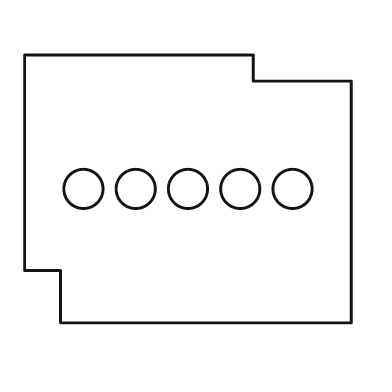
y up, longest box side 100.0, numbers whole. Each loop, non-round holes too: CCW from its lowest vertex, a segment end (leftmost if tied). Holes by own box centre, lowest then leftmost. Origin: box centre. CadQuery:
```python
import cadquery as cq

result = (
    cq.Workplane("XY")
    .moveTo(-39.0, -41.0)
    .lineTo(50.0, -41.0)
    .lineTo(50.0, 33.0)
    .lineTo(20.0, 33.0)
    .lineTo(20.0, 41.0)
    .lineTo(-50.0, 41.0)
    .lineTo(-50.0, -25.0)
    .lineTo(-39.0, -25.0)
    .close()
    .moveTo(-32.0, 0.0)
    .circle(6.0)
    .moveTo(-16.0, 0.0)
    .circle(6.0)
    .moveTo(0.0, 0.0)
    .circle(6.0)
    .moveTo(16.0, 0.0)
    .circle(6.0)
    .moveTo(32.0, 0.0)
    .circle(6.0)
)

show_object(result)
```